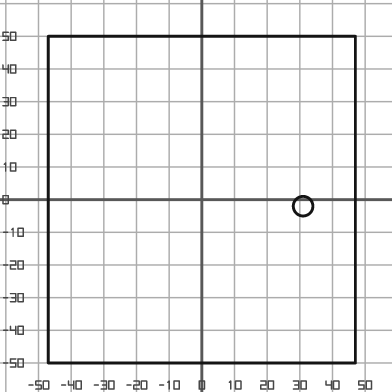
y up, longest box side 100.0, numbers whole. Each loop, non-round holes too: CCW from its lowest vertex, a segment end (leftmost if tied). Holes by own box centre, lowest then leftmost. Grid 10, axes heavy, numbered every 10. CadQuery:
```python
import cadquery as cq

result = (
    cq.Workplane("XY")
    .moveTo(-47.0, -50.0)
    .lineTo(47.0, -50.0)
    .lineTo(47.0, 50.0)
    .lineTo(-47.0, 50.0)
    .close()
    .moveTo(31.0, -2.0)
    .circle(3.0)
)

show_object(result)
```